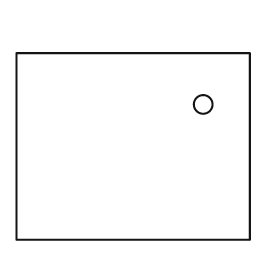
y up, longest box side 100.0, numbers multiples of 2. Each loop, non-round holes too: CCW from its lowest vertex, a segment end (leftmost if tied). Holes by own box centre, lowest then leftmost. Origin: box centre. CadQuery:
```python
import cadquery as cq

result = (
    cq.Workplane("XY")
    .moveTo(-50.0, -40.0)
    .lineTo(50.0, -40.0)
    .lineTo(50.0, 40.0)
    .lineTo(-50.0, 40.0)
    .close()
    .moveTo(30.0, 18.0)
    .circle(4.0)
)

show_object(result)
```